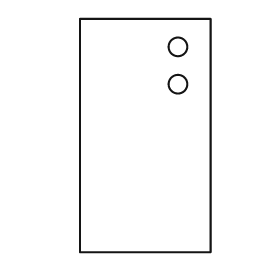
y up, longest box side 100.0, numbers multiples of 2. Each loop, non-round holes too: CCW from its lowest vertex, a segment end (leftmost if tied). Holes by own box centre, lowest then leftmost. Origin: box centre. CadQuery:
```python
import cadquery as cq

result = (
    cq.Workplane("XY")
    .moveTo(-28.0, -50.0)
    .lineTo(28.0, -50.0)
    .lineTo(28.0, 50.0)
    .lineTo(-28.0, 50.0)
    .close()
    .moveTo(14.0, 22.0)
    .circle(4.0)
    .moveTo(14.0, 38.0)
    .circle(4.0)
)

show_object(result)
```